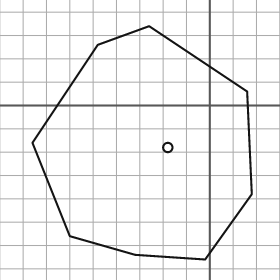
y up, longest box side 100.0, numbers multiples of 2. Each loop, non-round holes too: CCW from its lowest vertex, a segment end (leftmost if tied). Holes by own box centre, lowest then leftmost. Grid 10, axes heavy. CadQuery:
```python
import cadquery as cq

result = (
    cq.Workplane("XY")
    .moveTo(-2.0, -66.0)
    .lineTo(18.0, -38.0)
    .lineTo(16.0, 6.0)
    .lineTo(-26.0, 34.0)
    .lineTo(-48.0, 26.0)
    .lineTo(-76.0, -16.0)
    .lineTo(-60.0, -56.0)
    .lineTo(-32.0, -64.0)
    .close()
    .moveTo(-18.0, -18.0)
    .circle(2.0)
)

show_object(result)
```